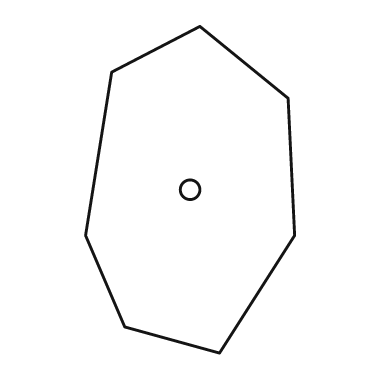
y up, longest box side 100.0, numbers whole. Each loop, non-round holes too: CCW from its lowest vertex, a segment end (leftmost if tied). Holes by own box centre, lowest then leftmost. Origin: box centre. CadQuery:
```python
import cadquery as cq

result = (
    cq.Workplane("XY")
    .moveTo(9.0, -50.0)
    .lineTo(32.0, -14.0)
    .lineTo(30.0, 28.0)
    .lineTo(3.0, 50.0)
    .lineTo(-24.0, 36.0)
    .lineTo(-32.0, -14.0)
    .lineTo(-20.0, -42.0)
    .close()
    .moveTo(0.0, 0.0)
    .circle(3.0)
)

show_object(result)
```